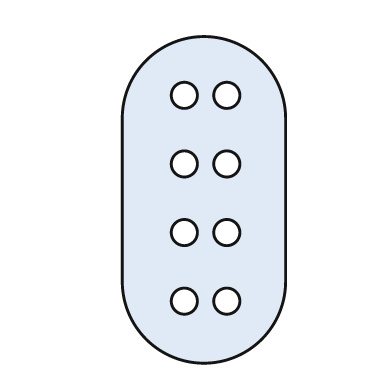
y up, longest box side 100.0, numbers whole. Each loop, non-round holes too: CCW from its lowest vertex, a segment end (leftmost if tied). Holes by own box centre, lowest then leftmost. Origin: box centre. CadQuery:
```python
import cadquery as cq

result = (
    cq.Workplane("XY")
    .moveTo(-25.0, -25.0)
    .threePointArc((0.0, -50.0), (25.0, -25.0))
    .lineTo(25.0, 25.0)
    .threePointArc((0.0, 50.0), (-25.0, 25.0))
    .close()
    .moveTo(-6.0, -31.0)
    .circle(4.0)
    .moveTo(7.0, -31.0)
    .circle(4.0)
    .moveTo(-6.0, -10.0)
    .circle(4.0)
    .moveTo(7.0, -10.0)
    .circle(4.0)
    .moveTo(-6.0, 11.0)
    .circle(4.0)
    .moveTo(7.0, 11.0)
    .circle(4.0)
    .moveTo(-6.0, 32.0)
    .circle(4.0)
    .moveTo(7.0, 32.0)
    .circle(4.0)
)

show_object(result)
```